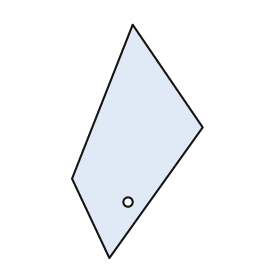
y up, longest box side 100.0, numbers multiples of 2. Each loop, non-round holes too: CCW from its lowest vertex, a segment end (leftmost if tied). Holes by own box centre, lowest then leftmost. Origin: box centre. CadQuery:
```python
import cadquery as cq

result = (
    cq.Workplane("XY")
    .moveTo(-12.0, -50.0)
    .lineTo(28.0, 6.0)
    .lineTo(-2.0, 50.0)
    .lineTo(-28.0, -16.0)
    .close()
    .moveTo(-4.0, -26.0)
    .circle(2.0)
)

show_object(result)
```